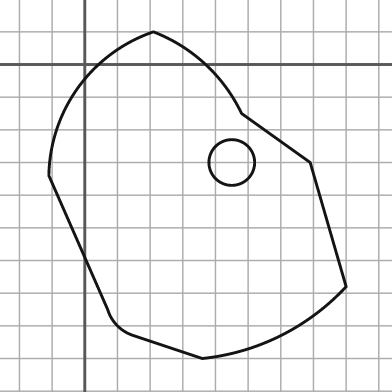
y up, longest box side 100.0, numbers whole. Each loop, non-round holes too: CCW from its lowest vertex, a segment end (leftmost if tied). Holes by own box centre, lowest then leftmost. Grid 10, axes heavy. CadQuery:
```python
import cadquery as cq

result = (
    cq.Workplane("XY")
    .moveTo(36.0, -90.0)
    .threePointArc((60.0, -83.0), (80.0, -68.0))
    .lineTo(69.0, -30.0)
    .lineTo(48.0, -15.0)
    .threePointArc((37.0, 0.0), (21.0, 10.0))
    .threePointArc((-2.0, -7.0), (-11.0, -34.0))
    .lineTo(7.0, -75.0)
    .threePointArc((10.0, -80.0), (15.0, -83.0))
    .close()
    .moveTo(45.0, -30.0)
    .circle(7.0)
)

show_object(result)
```